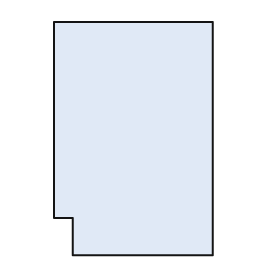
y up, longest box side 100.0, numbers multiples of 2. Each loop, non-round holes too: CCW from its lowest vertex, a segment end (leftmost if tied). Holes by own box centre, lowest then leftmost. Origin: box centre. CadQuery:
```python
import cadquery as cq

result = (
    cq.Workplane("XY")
    .moveTo(-26.0, -50.0)
    .lineTo(34.0, -50.0)
    .lineTo(34.0, 50.0)
    .lineTo(-34.0, 50.0)
    .lineTo(-34.0, -34.0)
    .lineTo(-26.0, -34.0)
    .close()
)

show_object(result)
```